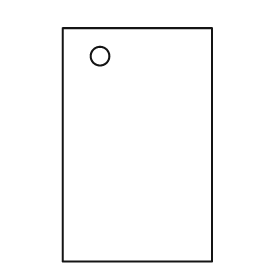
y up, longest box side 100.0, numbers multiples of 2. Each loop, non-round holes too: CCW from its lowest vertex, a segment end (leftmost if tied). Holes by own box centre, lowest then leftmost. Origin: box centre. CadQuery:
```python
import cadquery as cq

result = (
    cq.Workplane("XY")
    .moveTo(-32.0, -50.0)
    .lineTo(32.0, -50.0)
    .lineTo(32.0, 50.0)
    .lineTo(-32.0, 50.0)
    .close()
    .moveTo(-16.0, 38.0)
    .circle(4.0)
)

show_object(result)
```